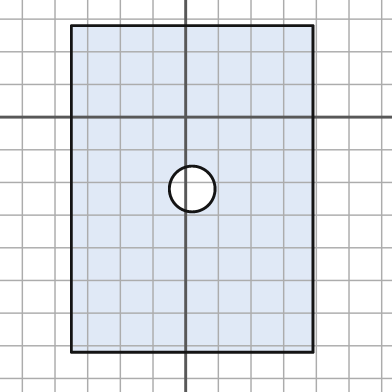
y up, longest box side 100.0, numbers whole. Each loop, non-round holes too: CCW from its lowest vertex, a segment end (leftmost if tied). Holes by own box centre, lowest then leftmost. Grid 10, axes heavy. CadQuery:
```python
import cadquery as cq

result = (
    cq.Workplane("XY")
    .moveTo(-35.0, -72.0)
    .lineTo(39.0, -72.0)
    .lineTo(39.0, 28.0)
    .lineTo(-35.0, 28.0)
    .close()
    .moveTo(2.0, -22.0)
    .circle(7.0)
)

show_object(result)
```